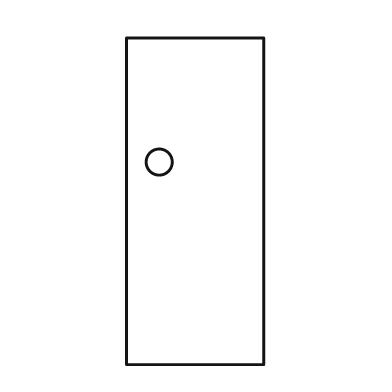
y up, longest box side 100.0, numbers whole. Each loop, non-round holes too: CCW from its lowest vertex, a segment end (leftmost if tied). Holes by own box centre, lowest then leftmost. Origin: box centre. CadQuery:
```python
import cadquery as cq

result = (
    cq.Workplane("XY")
    .moveTo(-21.0, -50.0)
    .lineTo(21.0, -50.0)
    .lineTo(21.0, 50.0)
    .lineTo(-21.0, 50.0)
    .close()
    .moveTo(-11.0, 12.0)
    .circle(4.0)
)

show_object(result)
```